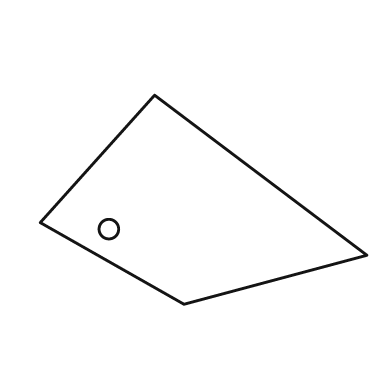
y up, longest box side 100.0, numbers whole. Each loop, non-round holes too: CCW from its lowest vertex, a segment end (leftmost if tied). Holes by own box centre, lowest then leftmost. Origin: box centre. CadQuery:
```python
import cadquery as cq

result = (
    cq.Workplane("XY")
    .moveTo(-6.0, -32.0)
    .lineTo(50.0, -17.0)
    .lineTo(-15.0, 32.0)
    .lineTo(-50.0, -7.0)
    .close()
    .moveTo(-29.0, -9.0)
    .circle(3.0)
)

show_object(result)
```